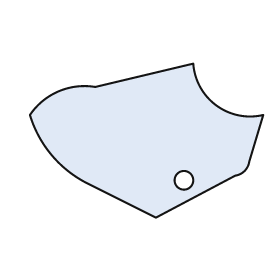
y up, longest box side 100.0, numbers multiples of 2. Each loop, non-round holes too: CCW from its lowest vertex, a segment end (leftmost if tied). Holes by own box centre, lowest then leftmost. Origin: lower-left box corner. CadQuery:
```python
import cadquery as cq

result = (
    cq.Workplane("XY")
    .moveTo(54.0, 0.0)
    .lineTo(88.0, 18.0)
    .threePointArc((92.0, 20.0), (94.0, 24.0))
    .lineTo(100.0, 44.0)
    .threePointArc((80.0, 48.0), (70.0, 66.0))
    .lineTo(28.0, 56.0)
    .threePointArc((12.0, 54.0), (0.0, 44.0))
    .threePointArc((10.0, 26.0), (26.0, 14.0))
    .close()
    .moveTo(66.0, 16.0)
    .circle(4.0)
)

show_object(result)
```